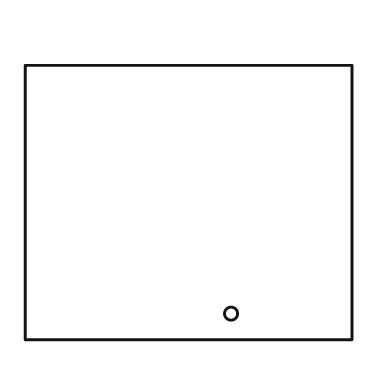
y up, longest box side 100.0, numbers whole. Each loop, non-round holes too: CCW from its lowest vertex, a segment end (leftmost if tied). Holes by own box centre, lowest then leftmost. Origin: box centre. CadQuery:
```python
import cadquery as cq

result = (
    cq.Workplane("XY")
    .moveTo(-50.0, -42.0)
    .lineTo(50.0, -42.0)
    .lineTo(50.0, 42.0)
    .lineTo(-50.0, 42.0)
    .close()
    .moveTo(13.0, -34.0)
    .circle(2.0)
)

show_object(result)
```